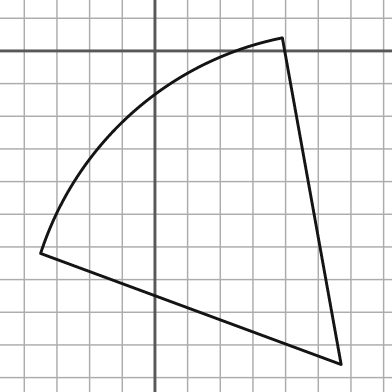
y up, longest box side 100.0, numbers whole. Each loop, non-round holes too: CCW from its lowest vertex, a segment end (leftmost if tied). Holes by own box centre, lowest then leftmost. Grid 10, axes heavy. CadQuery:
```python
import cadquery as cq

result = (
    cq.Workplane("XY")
    .moveTo(57.0, -96.0)
    .lineTo(39.0, 4.0)
    .threePointArc((-7.0, -19.0), (-35.0, -62.0))
    .close()
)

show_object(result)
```